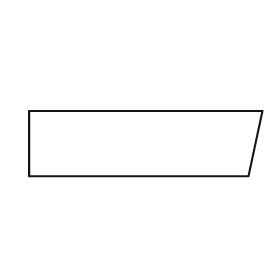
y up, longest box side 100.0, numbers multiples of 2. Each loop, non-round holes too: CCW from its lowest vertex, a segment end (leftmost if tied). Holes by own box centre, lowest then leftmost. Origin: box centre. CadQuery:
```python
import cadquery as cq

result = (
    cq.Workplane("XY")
    .moveTo(-50.0, -14.0)
    .lineTo(44.0, -14.0)
    .lineTo(50.0, 14.0)
    .lineTo(-50.0, 14.0)
    .close()
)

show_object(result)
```